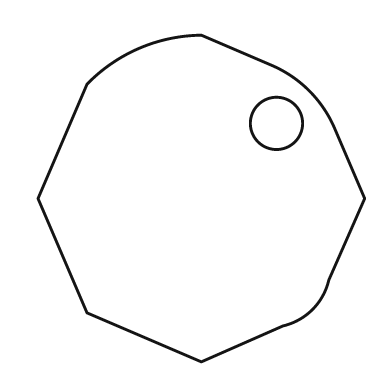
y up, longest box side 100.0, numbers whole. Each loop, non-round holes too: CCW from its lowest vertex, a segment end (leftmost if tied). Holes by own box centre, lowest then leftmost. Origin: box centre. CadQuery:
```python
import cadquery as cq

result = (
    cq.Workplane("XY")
    .moveTo(0.0, -50.0)
    .lineTo(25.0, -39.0)
    .threePointArc((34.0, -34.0), (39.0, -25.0))
    .lineTo(50.0, 0.0)
    .lineTo(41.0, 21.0)
    .threePointArc((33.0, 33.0), (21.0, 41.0))
    .lineTo(0.0, 50.0)
    .threePointArc((-19.0, 46.0), (-35.0, 35.0))
    .lineTo(-50.0, 0.0)
    .lineTo(-35.0, -35.0)
    .close()
    .moveTo(23.0, 23.0)
    .circle(8.0)
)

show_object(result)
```